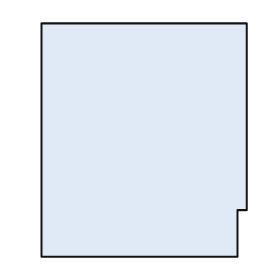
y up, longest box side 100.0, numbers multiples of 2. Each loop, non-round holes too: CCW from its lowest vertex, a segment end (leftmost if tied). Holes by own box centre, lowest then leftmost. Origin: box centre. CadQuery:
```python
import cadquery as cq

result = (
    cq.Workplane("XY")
    .moveTo(-44.0, -50.0)
    .lineTo(40.0, -50.0)
    .lineTo(40.0, -30.0)
    .lineTo(44.0, -30.0)
    .lineTo(44.0, 50.0)
    .lineTo(-44.0, 50.0)
    .close()
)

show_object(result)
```